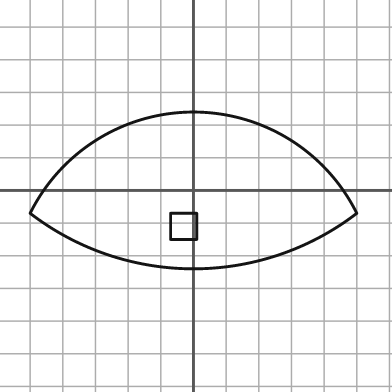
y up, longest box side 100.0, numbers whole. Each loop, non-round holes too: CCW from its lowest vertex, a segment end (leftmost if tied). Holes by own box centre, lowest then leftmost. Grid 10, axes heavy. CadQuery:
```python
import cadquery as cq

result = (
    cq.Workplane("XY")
    .moveTo(-50.0, -7.0)
    .threePointArc((0.0, -24.0), (50.0, -7.0))
    .threePointArc((0.0, 24.0), (-50.0, -7.0))
    .close()
    .moveTo(-7.0, -15.0)
    .lineTo(1.0, -15.0)
    .lineTo(1.0, -7.0)
    .lineTo(-7.0, -7.0)
    .close()
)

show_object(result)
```